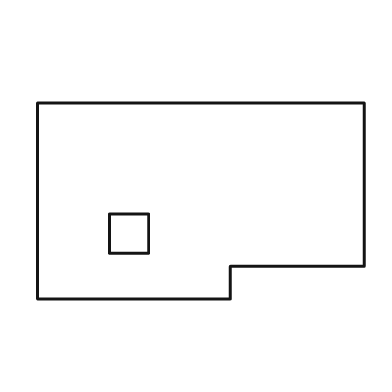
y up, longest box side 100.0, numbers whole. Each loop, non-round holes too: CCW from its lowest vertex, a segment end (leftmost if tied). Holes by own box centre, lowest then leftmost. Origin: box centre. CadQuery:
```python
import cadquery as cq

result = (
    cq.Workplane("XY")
    .moveTo(-50.0, -30.0)
    .lineTo(9.0, -30.0)
    .lineTo(9.0, -20.0)
    .lineTo(50.0, -20.0)
    .lineTo(50.0, 30.0)
    .lineTo(-50.0, 30.0)
    .close()
    .moveTo(-28.0, -16.0)
    .lineTo(-16.0, -16.0)
    .lineTo(-16.0, -4.0)
    .lineTo(-28.0, -4.0)
    .close()
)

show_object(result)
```